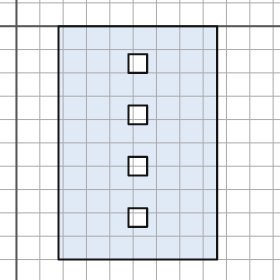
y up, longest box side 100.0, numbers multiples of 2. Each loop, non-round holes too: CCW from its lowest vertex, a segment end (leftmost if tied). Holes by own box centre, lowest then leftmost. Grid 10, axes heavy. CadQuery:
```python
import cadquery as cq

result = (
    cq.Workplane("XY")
    .moveTo(18.0, -100.0)
    .lineTo(86.0, -100.0)
    .lineTo(86.0, 0.0)
    .lineTo(18.0, 0.0)
    .close()
    .moveTo(48.0, -86.0)
    .lineTo(56.0, -86.0)
    .lineTo(56.0, -78.0)
    .lineTo(48.0, -78.0)
    .close()
    .moveTo(48.0, -64.0)
    .lineTo(56.0, -64.0)
    .lineTo(56.0, -56.0)
    .lineTo(48.0, -56.0)
    .close()
    .moveTo(48.0, -42.0)
    .lineTo(56.0, -42.0)
    .lineTo(56.0, -34.0)
    .lineTo(48.0, -34.0)
    .close()
    .moveTo(48.0, -20.0)
    .lineTo(56.0, -20.0)
    .lineTo(56.0, -12.0)
    .lineTo(48.0, -12.0)
    .close()
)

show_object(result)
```